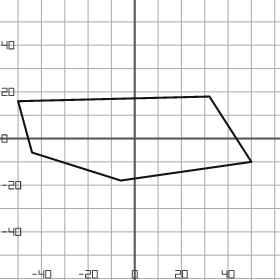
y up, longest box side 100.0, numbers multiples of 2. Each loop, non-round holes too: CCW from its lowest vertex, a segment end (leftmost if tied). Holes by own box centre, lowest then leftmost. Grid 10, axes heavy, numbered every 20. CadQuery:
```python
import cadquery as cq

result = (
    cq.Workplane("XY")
    .moveTo(-6.0, -18.0)
    .lineTo(50.0, -10.0)
    .lineTo(32.0, 18.0)
    .lineTo(-50.0, 16.0)
    .lineTo(-44.0, -6.0)
    .close()
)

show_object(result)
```